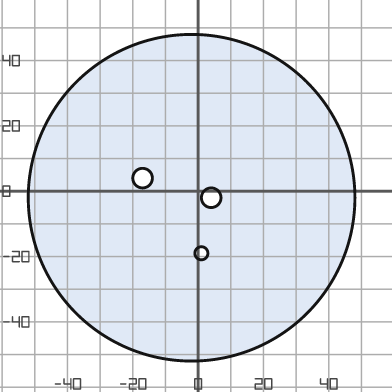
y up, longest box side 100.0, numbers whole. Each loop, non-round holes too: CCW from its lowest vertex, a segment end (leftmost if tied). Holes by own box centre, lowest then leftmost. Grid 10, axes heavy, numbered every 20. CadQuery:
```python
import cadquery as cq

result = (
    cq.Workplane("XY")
    .moveTo(-2.0, -2.0)
    .circle(50.0)
    .moveTo(1.0, -19.0)
    .circle(2.0)
    .moveTo(4.0, -2.0)
    .circle(3.0)
    .moveTo(-17.0, 4.0)
    .circle(3.0)
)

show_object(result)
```